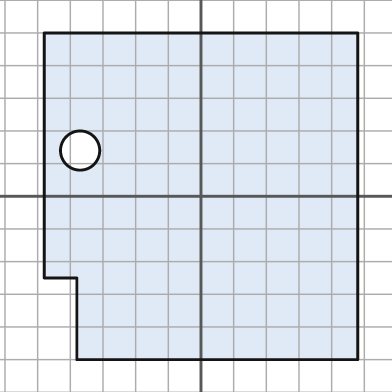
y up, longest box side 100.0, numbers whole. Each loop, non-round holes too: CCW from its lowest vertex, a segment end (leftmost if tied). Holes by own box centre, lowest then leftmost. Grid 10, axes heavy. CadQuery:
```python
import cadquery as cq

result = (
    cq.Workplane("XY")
    .moveTo(-38.0, -50.0)
    .lineTo(48.0, -50.0)
    .lineTo(48.0, 50.0)
    .lineTo(-48.0, 50.0)
    .lineTo(-48.0, -25.0)
    .lineTo(-38.0, -25.0)
    .close()
    .moveTo(-37.0, 14.0)
    .circle(6.0)
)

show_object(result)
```